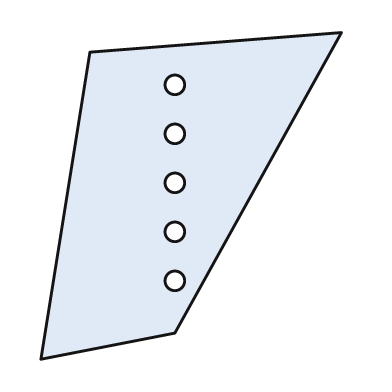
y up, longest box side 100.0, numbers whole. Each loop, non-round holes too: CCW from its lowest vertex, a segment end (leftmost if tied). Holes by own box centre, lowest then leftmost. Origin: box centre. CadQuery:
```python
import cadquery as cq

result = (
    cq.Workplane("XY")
    .moveTo(-46.0, -50.0)
    .lineTo(-5.0, -42.0)
    .lineTo(46.0, 50.0)
    .lineTo(-31.0, 44.0)
    .close()
    .moveTo(-5.0, -26.0)
    .circle(3.0)
    .moveTo(-5.0, -11.0)
    .circle(3.0)
    .moveTo(-5.0, 4.0)
    .circle(3.0)
    .moveTo(-5.0, 19.0)
    .circle(3.0)
    .moveTo(-5.0, 34.0)
    .circle(3.0)
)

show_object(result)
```